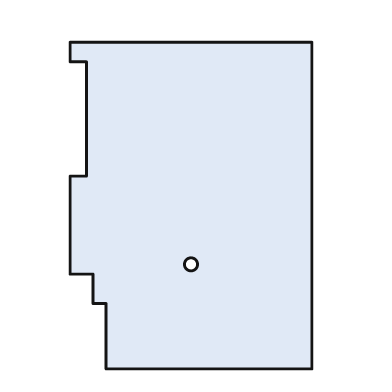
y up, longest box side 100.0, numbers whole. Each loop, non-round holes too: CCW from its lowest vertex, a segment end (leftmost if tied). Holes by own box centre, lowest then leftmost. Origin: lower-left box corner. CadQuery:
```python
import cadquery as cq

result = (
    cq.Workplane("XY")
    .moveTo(11.0, 0.0)
    .lineTo(74.0, 0.0)
    .lineTo(74.0, 100.0)
    .lineTo(0.0, 100.0)
    .lineTo(0.0, 94.0)
    .lineTo(5.0, 94.0)
    .lineTo(5.0, 59.0)
    .lineTo(0.0, 59.0)
    .lineTo(0.0, 29.0)
    .lineTo(7.0, 29.0)
    .lineTo(7.0, 20.0)
    .lineTo(11.0, 20.0)
    .close()
    .moveTo(37.0, 32.0)
    .circle(2.0)
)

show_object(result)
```